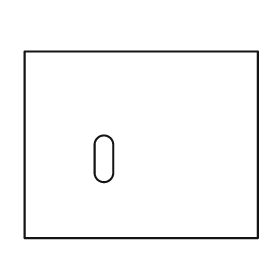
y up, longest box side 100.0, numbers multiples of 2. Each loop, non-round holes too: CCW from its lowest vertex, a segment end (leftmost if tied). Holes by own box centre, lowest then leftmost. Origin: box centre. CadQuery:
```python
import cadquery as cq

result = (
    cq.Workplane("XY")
    .moveTo(-50.0, -40.0)
    .lineTo(50.0, -40.0)
    .lineTo(50.0, 40.0)
    .lineTo(-50.0, 40.0)
    .close()
    .moveTo(-20.0, -12.0)
    .threePointArc((-16.0, -16.0), (-12.0, -12.0))
    .lineTo(-12.0, 0.0)
    .threePointArc((-16.0, 4.0), (-20.0, 0.0))
    .close()
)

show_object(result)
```